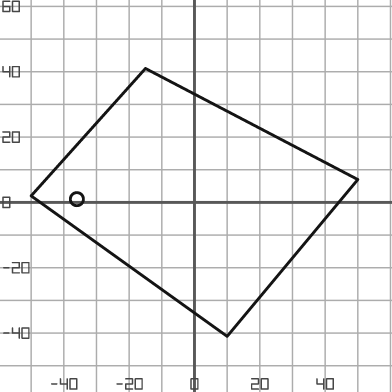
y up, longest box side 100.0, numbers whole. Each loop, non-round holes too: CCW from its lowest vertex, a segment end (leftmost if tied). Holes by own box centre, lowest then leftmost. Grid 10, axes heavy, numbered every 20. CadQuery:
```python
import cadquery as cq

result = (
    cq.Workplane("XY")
    .moveTo(10.0, -41.0)
    .lineTo(50.0, 7.0)
    .lineTo(-15.0, 41.0)
    .lineTo(-50.0, 2.0)
    .close()
    .moveTo(-36.0, 1.0)
    .circle(2.0)
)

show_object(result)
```